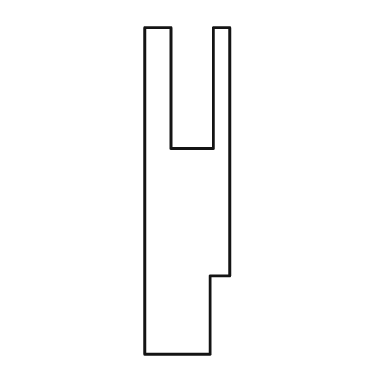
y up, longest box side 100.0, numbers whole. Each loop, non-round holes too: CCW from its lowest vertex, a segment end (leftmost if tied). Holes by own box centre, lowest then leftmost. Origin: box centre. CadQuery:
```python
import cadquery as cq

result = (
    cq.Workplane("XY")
    .moveTo(-13.0, -50.0)
    .lineTo(7.0, -50.0)
    .lineTo(7.0, -26.0)
    .lineTo(13.0, -26.0)
    .lineTo(13.0, 50.0)
    .lineTo(8.0, 50.0)
    .lineTo(8.0, 13.0)
    .lineTo(-5.0, 13.0)
    .lineTo(-5.0, 50.0)
    .lineTo(-13.0, 50.0)
    .close()
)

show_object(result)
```